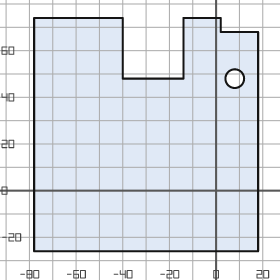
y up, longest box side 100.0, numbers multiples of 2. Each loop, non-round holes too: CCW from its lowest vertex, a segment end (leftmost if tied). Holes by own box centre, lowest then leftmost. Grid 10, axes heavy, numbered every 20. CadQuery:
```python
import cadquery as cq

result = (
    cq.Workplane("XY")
    .moveTo(-78.0, -26.0)
    .lineTo(18.0, -26.0)
    .lineTo(18.0, 68.0)
    .lineTo(2.0, 68.0)
    .lineTo(2.0, 74.0)
    .lineTo(-14.0, 74.0)
    .lineTo(-14.0, 48.0)
    .lineTo(-40.0, 48.0)
    .lineTo(-40.0, 74.0)
    .lineTo(-78.0, 74.0)
    .close()
    .moveTo(8.0, 48.0)
    .circle(4.0)
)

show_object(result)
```